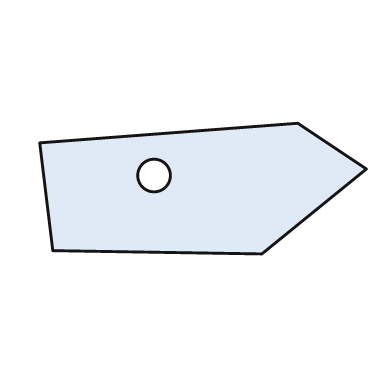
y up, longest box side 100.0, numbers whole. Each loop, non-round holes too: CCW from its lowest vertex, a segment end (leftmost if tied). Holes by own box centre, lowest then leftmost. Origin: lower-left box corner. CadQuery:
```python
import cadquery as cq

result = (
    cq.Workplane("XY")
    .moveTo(68.0, 0.0)
    .lineTo(100.0, 26.0)
    .lineTo(79.0, 40.0)
    .lineTo(0.0, 34.0)
    .lineTo(4.0, 1.0)
    .close()
    .moveTo(35.0, 24.0)
    .circle(5.0)
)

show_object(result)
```